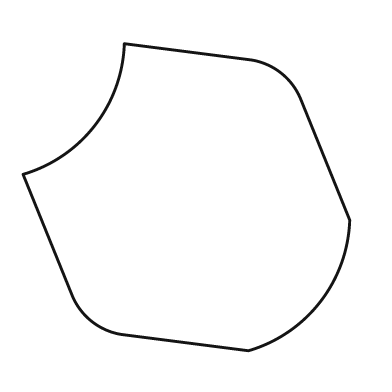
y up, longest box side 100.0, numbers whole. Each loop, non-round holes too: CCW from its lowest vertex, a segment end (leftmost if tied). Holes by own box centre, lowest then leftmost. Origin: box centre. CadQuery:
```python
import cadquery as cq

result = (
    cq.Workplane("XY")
    .moveTo(19.0, -47.0)
    .threePointArc((41.0, -32.0), (50.0, -7.0))
    .lineTo(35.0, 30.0)
    .threePointArc((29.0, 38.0), (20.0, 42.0))
    .lineTo(-19.0, 47.0)
    .threePointArc((-28.0, 22.0), (-50.0, 7.0))
    .lineTo(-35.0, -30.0)
    .threePointArc((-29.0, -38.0), (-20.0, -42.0))
    .close()
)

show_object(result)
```